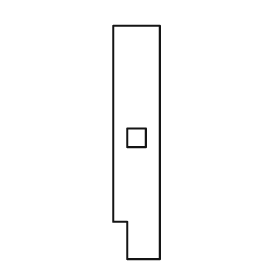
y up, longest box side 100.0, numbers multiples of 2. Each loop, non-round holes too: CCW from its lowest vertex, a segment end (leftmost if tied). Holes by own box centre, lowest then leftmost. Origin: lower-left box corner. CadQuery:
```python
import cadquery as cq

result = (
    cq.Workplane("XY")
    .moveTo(6.0, 0.0)
    .lineTo(20.0, 0.0)
    .lineTo(20.0, 100.0)
    .lineTo(0.0, 100.0)
    .lineTo(0.0, 16.0)
    .lineTo(6.0, 16.0)
    .close()
    .moveTo(6.0, 48.0)
    .lineTo(14.0, 48.0)
    .lineTo(14.0, 56.0)
    .lineTo(6.0, 56.0)
    .close()
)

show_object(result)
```